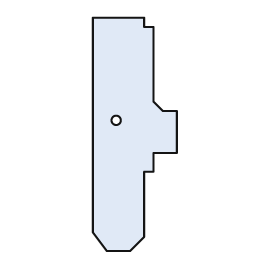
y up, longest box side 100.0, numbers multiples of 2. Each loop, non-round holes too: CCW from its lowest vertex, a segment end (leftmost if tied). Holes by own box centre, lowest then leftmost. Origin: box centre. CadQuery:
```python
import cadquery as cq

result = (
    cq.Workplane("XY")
    .moveTo(-12.0, -50.0)
    .lineTo(-2.0, -50.0)
    .lineTo(4.0, -44.0)
    .lineTo(4.0, -16.0)
    .lineTo(8.0, -16.0)
    .lineTo(8.0, -8.0)
    .lineTo(18.0, -8.0)
    .lineTo(18.0, 10.0)
    .lineTo(12.0, 10.0)
    .lineTo(8.0, 14.0)
    .lineTo(8.0, 46.0)
    .lineTo(4.0, 46.0)
    .lineTo(4.0, 50.0)
    .lineTo(-18.0, 50.0)
    .lineTo(-18.0, -42.0)
    .close()
    .moveTo(-8.0, 6.0)
    .circle(2.0)
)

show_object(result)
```